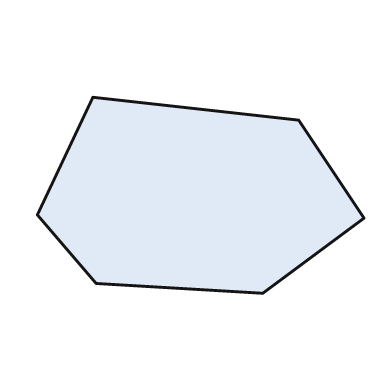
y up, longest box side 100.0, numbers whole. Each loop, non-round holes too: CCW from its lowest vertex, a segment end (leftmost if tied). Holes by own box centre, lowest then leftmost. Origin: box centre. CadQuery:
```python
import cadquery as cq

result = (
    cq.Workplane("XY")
    .moveTo(19.0, -30.0)
    .lineTo(50.0, -7.0)
    .lineTo(30.0, 23.0)
    .lineTo(-33.0, 30.0)
    .lineTo(-50.0, -6.0)
    .lineTo(-32.0, -27.0)
    .close()
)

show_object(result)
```